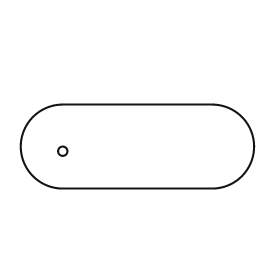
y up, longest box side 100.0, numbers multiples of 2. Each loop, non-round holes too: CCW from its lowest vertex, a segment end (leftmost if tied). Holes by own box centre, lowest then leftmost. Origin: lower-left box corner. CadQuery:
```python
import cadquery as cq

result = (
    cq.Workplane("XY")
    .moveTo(18.0, 0.0)
    .lineTo(82.0, 0.0)
    .threePointArc((100.0, 18.0), (82.0, 36.0))
    .lineTo(18.0, 36.0)
    .threePointArc((0.0, 18.0), (18.0, 0.0))
    .close()
    .moveTo(18.0, 16.0)
    .circle(2.0)
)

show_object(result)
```